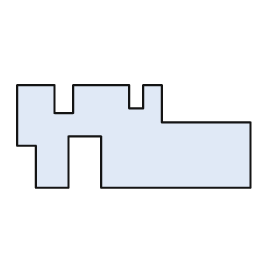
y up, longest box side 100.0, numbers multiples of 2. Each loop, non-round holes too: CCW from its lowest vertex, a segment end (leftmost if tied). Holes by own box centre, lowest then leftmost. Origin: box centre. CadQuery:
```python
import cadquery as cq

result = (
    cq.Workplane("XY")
    .moveTo(-42.0, -22.0)
    .lineTo(-28.0, -22.0)
    .lineTo(-28.0, 0.0)
    .lineTo(-14.0, 0.0)
    .lineTo(-14.0, -22.0)
    .lineTo(50.0, -22.0)
    .lineTo(50.0, 6.0)
    .lineTo(12.0, 6.0)
    .lineTo(12.0, 22.0)
    .lineTo(4.0, 22.0)
    .lineTo(4.0, 12.0)
    .lineTo(-2.0, 12.0)
    .lineTo(-2.0, 22.0)
    .lineTo(-26.0, 22.0)
    .lineTo(-26.0, 10.0)
    .lineTo(-34.0, 10.0)
    .lineTo(-34.0, 22.0)
    .lineTo(-50.0, 22.0)
    .lineTo(-50.0, -4.0)
    .lineTo(-42.0, -4.0)
    .close()
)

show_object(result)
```